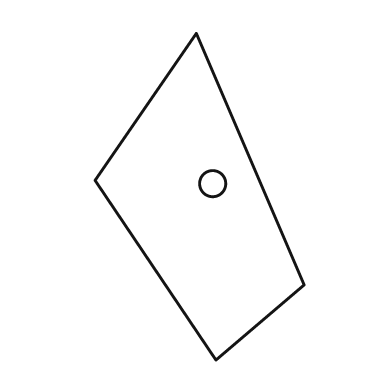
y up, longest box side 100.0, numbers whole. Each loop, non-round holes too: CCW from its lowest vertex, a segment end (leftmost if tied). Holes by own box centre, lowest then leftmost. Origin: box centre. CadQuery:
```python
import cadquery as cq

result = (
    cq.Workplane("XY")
    .moveTo(5.0, -50.0)
    .lineTo(32.0, -27.0)
    .lineTo(-1.0, 50.0)
    .lineTo(-32.0, 5.0)
    .close()
    .moveTo(4.0, 4.0)
    .circle(4.0)
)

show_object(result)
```